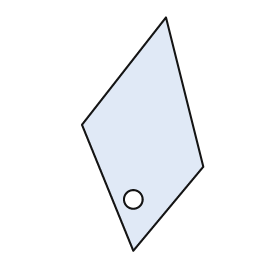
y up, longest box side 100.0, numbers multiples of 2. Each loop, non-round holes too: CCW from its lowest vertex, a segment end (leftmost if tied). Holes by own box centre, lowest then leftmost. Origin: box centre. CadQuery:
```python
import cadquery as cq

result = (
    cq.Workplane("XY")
    .moveTo(-4.0, -50.0)
    .lineTo(26.0, -14.0)
    .lineTo(10.0, 50.0)
    .lineTo(-26.0, 4.0)
    .close()
    .moveTo(-4.0, -28.0)
    .circle(4.0)
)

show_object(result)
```